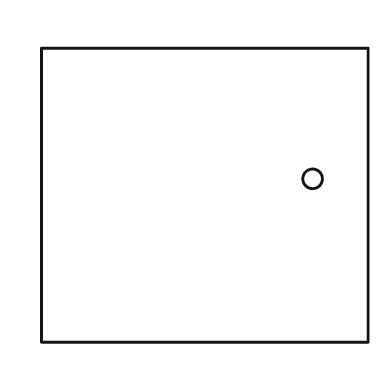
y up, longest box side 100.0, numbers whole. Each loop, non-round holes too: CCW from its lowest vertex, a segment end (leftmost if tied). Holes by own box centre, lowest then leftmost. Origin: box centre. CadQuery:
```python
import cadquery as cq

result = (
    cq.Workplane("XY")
    .moveTo(-50.0, -45.0)
    .lineTo(50.0, -45.0)
    .lineTo(50.0, 45.0)
    .lineTo(-50.0, 45.0)
    .close()
    .moveTo(33.0, 5.0)
    .circle(3.0)
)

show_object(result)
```